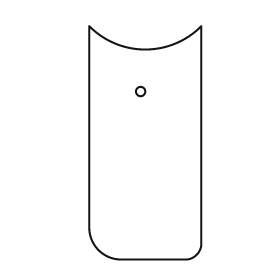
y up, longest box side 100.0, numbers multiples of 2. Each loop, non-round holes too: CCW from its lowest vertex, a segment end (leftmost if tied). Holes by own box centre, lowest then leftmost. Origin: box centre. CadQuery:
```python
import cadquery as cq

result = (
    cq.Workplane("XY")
    .moveTo(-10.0, -50.0)
    .lineTo(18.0, -50.0)
    .threePointArc((22.0, -48.0), (24.0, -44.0))
    .lineTo(24.0, 50.0)
    .threePointArc((0.0, 40.0), (-24.0, 50.0))
    .lineTo(-24.0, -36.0)
    .threePointArc((-20.0, -46.0), (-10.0, -50.0))
    .close()
    .moveTo(-2.0, 22.0)
    .circle(2.0)
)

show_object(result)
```